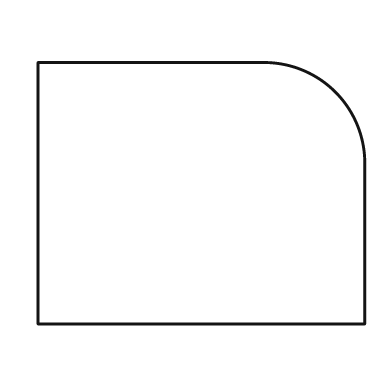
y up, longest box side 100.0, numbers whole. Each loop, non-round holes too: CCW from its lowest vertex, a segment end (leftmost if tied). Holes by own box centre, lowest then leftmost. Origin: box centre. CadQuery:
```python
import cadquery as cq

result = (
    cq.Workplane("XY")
    .moveTo(-50.0, -40.0)
    .lineTo(50.0, -40.0)
    .lineTo(50.0, 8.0)
    .threePointArc((41.0, 31.0), (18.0, 40.0))
    .lineTo(-50.0, 40.0)
    .close()
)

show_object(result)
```